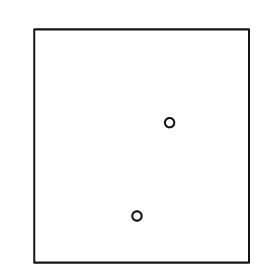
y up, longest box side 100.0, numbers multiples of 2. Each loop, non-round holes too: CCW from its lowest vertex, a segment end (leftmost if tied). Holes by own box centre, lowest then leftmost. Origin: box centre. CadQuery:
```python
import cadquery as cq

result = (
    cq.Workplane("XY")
    .moveTo(-46.0, -50.0)
    .lineTo(46.0, -50.0)
    .lineTo(46.0, 50.0)
    .lineTo(-46.0, 50.0)
    .close()
    .moveTo(-2.0, -30.0)
    .circle(2.0)
    .moveTo(12.0, 10.0)
    .circle(2.0)
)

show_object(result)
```